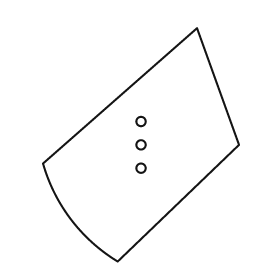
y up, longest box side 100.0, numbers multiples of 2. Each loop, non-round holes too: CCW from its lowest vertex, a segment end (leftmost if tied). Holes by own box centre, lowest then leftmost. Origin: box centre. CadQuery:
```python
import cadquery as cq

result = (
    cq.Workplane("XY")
    .moveTo(-10.0, -50.0)
    .lineTo(42.0, 0.0)
    .lineTo(24.0, 50.0)
    .lineTo(-42.0, -8.0)
    .threePointArc((-30.0, -32.0), (-10.0, -50.0))
    .close()
    .moveTo(0.0, -10.0)
    .circle(2.0)
    .moveTo(0.0, 0.0)
    .circle(2.0)
    .moveTo(0.0, 10.0)
    .circle(2.0)
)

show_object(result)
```